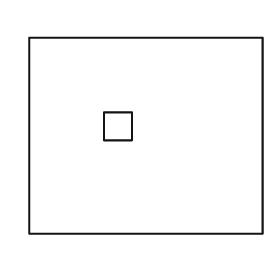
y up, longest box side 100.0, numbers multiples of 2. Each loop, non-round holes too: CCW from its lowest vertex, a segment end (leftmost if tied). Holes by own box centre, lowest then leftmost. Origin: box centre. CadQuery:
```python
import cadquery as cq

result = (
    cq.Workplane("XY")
    .moveTo(-50.0, -42.0)
    .lineTo(50.0, -42.0)
    .lineTo(50.0, 42.0)
    .lineTo(-50.0, 42.0)
    .close()
    .moveTo(-18.0, -2.0)
    .lineTo(-6.0, -2.0)
    .lineTo(-6.0, 10.0)
    .lineTo(-18.0, 10.0)
    .close()
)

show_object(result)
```